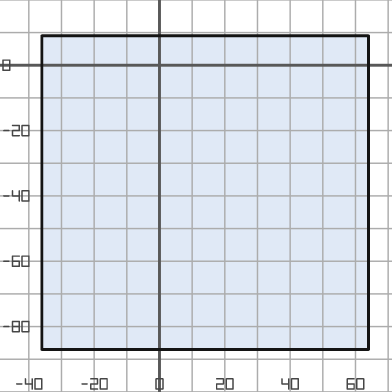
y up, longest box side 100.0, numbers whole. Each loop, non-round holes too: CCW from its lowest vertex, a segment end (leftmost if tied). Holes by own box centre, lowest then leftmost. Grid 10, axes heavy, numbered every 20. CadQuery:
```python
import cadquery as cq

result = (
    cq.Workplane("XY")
    .moveTo(-36.0, -87.0)
    .lineTo(64.0, -87.0)
    .lineTo(64.0, 9.0)
    .lineTo(-36.0, 9.0)
    .close()
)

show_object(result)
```